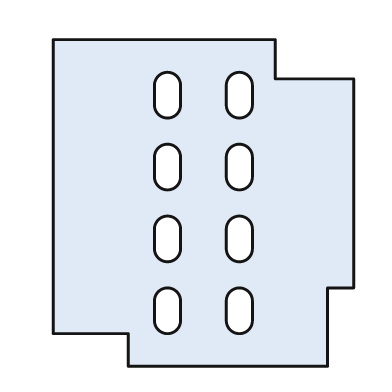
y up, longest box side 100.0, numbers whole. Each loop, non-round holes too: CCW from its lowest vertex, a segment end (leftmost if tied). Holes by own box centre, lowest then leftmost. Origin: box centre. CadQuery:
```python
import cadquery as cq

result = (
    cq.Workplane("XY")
    .moveTo(-23.0, -50.0)
    .lineTo(38.0, -50.0)
    .lineTo(38.0, -26.0)
    .lineTo(46.0, -26.0)
    .lineTo(46.0, 38.0)
    .lineTo(22.0, 38.0)
    .lineTo(22.0, 50.0)
    .lineTo(-46.0, 50.0)
    .lineTo(-46.0, -40.0)
    .lineTo(-23.0, -40.0)
    .close()
    .moveTo(-15.0, -36.0)
    .threePointArc((-11.0, -40.0), (-7.0, -36.0))
    .lineTo(-7.0, -30.0)
    .threePointArc((-11.0, -26.0), (-15.0, -30.0))
    .close()
    .moveTo(7.0, -36.0)
    .threePointArc((11.0, -40.0), (15.0, -36.0))
    .lineTo(15.0, -30.0)
    .threePointArc((11.0, -26.0), (7.0, -30.0))
    .close()
    .moveTo(-15.0, -14.0)
    .threePointArc((-11.0, -18.0), (-7.0, -14.0))
    .lineTo(-7.0, -8.0)
    .threePointArc((-11.0, -4.0), (-15.0, -8.0))
    .close()
    .moveTo(7.0, -14.0)
    .threePointArc((11.0, -18.0), (15.0, -14.0))
    .lineTo(15.0, -8.0)
    .threePointArc((11.0, -4.0), (7.0, -8.0))
    .close()
    .moveTo(-15.0, 8.0)
    .threePointArc((-11.0, 4.0), (-7.0, 8.0))
    .lineTo(-7.0, 14.0)
    .threePointArc((-11.0, 18.0), (-15.0, 14.0))
    .close()
    .moveTo(7.0, 8.0)
    .threePointArc((11.0, 4.0), (15.0, 8.0))
    .lineTo(15.0, 14.0)
    .threePointArc((11.0, 18.0), (7.0, 14.0))
    .close()
    .moveTo(-15.0, 30.0)
    .threePointArc((-11.0, 26.0), (-7.0, 30.0))
    .lineTo(-7.0, 36.0)
    .threePointArc((-11.0, 40.0), (-15.0, 36.0))
    .close()
    .moveTo(7.0, 30.0)
    .threePointArc((11.0, 26.0), (15.0, 30.0))
    .lineTo(15.0, 36.0)
    .threePointArc((11.0, 40.0), (7.0, 36.0))
    .close()
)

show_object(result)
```